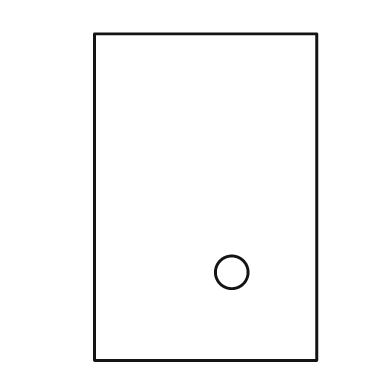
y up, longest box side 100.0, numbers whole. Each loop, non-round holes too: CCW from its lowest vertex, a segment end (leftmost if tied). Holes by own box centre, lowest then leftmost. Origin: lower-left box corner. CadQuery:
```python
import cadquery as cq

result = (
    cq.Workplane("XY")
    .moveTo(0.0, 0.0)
    .lineTo(68.0, 0.0)
    .lineTo(68.0, 100.0)
    .lineTo(0.0, 100.0)
    .close()
    .moveTo(42.0, 27.0)
    .circle(5.0)
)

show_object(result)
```